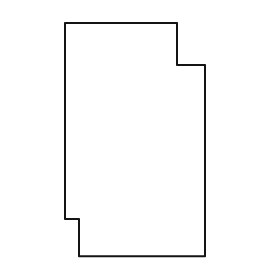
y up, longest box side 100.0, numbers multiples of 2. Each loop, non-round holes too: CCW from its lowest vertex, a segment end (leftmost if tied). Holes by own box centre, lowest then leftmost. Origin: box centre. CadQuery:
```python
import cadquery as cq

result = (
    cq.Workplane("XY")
    .moveTo(-24.0, -50.0)
    .lineTo(30.0, -50.0)
    .lineTo(30.0, 32.0)
    .lineTo(18.0, 32.0)
    .lineTo(18.0, 50.0)
    .lineTo(-30.0, 50.0)
    .lineTo(-30.0, -34.0)
    .lineTo(-24.0, -34.0)
    .close()
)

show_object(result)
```